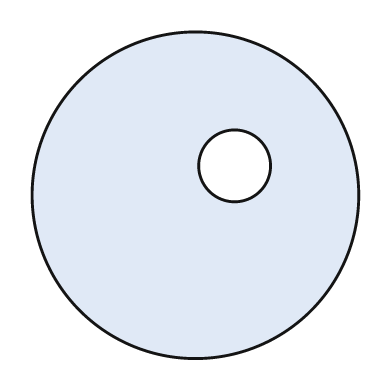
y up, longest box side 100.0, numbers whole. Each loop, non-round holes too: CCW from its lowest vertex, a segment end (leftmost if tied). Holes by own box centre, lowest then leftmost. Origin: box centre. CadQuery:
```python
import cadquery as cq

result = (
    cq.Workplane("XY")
    .moveTo(0.0, 0.0)
    .circle(50.0)
    .moveTo(12.0, 9.0)
    .circle(11.0)
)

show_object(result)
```